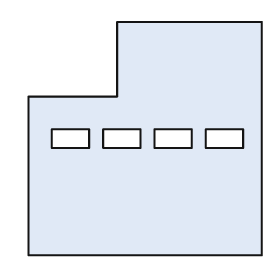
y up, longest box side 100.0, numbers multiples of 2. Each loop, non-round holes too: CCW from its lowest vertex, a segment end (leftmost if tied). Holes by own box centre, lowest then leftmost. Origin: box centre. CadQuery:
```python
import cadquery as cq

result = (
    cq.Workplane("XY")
    .moveTo(-50.0, -50.0)
    .lineTo(50.0, -50.0)
    .lineTo(50.0, 50.0)
    .lineTo(-12.0, 50.0)
    .lineTo(-12.0, 18.0)
    .lineTo(-50.0, 18.0)
    .close()
    .moveTo(-40.0, -4.0)
    .lineTo(-24.0, -4.0)
    .lineTo(-24.0, 4.0)
    .lineTo(-40.0, 4.0)
    .close()
    .moveTo(-18.0, -4.0)
    .lineTo(-2.0, -4.0)
    .lineTo(-2.0, 4.0)
    .lineTo(-18.0, 4.0)
    .close()
    .moveTo(4.0, -4.0)
    .lineTo(20.0, -4.0)
    .lineTo(20.0, 4.0)
    .lineTo(4.0, 4.0)
    .close()
    .moveTo(26.0, -4.0)
    .lineTo(42.0, -4.0)
    .lineTo(42.0, 4.0)
    .lineTo(26.0, 4.0)
    .close()
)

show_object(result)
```